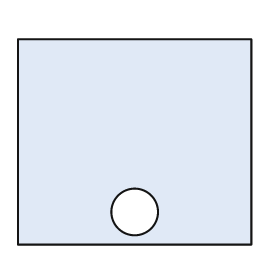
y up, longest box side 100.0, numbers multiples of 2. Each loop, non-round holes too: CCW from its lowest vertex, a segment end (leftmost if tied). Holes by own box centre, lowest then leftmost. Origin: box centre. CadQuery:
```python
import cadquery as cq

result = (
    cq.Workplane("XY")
    .moveTo(-50.0, -44.0)
    .lineTo(50.0, -44.0)
    .lineTo(50.0, 44.0)
    .lineTo(-50.0, 44.0)
    .close()
    .moveTo(0.0, -30.0)
    .circle(10.0)
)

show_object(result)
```